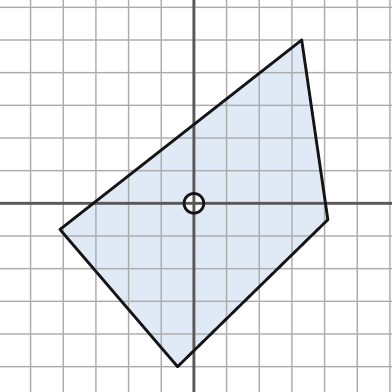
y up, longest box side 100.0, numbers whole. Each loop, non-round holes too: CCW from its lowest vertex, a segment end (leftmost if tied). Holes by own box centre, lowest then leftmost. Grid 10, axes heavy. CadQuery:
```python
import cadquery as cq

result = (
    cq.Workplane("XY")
    .moveTo(-5.0, -50.0)
    .lineTo(41.0, -5.0)
    .lineTo(33.0, 50.0)
    .lineTo(-41.0, -8.0)
    .close()
    .moveTo(0.0, 0.0)
    .circle(3.0)
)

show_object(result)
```